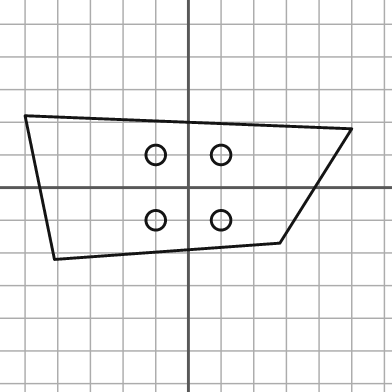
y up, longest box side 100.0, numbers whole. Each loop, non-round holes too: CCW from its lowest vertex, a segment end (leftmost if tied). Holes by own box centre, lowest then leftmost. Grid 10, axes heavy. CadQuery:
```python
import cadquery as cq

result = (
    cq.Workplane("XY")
    .moveTo(-41.0, -22.0)
    .lineTo(28.0, -17.0)
    .lineTo(50.0, 18.0)
    .lineTo(-50.0, 22.0)
    .close()
    .moveTo(-10.0, -10.0)
    .circle(3.0)
    .moveTo(10.0, -10.0)
    .circle(3.0)
    .moveTo(-10.0, 10.0)
    .circle(3.0)
    .moveTo(10.0, 10.0)
    .circle(3.0)
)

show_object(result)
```